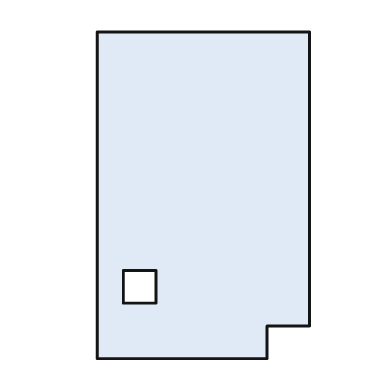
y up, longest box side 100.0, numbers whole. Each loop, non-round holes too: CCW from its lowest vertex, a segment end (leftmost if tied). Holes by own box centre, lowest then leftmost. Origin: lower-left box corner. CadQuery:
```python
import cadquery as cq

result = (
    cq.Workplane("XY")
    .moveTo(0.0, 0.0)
    .lineTo(52.0, 0.0)
    .lineTo(52.0, 10.0)
    .lineTo(65.0, 10.0)
    .lineTo(65.0, 100.0)
    .lineTo(0.0, 100.0)
    .close()
    .moveTo(8.0, 17.0)
    .lineTo(18.0, 17.0)
    .lineTo(18.0, 27.0)
    .lineTo(8.0, 27.0)
    .close()
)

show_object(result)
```